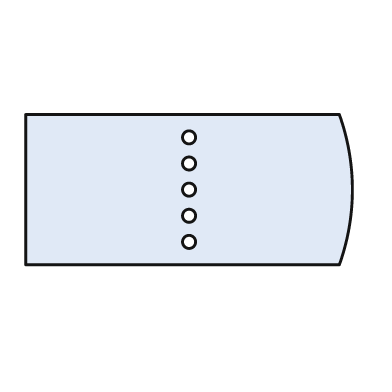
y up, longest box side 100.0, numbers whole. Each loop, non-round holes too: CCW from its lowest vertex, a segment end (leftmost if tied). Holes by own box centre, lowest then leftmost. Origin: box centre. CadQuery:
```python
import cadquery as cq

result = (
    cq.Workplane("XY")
    .moveTo(-50.0, -23.0)
    .lineTo(46.0, -23.0)
    .threePointArc((50.0, 0.0), (46.0, 23.0))
    .lineTo(-50.0, 23.0)
    .close()
    .moveTo(0.0, -16.0)
    .circle(2.0)
    .moveTo(0.0, -8.0)
    .circle(2.0)
    .moveTo(0.0, 0.0)
    .circle(2.0)
    .moveTo(0.0, 8.0)
    .circle(2.0)
    .moveTo(0.0, 16.0)
    .circle(2.0)
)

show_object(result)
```